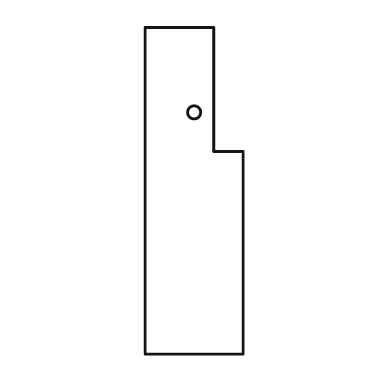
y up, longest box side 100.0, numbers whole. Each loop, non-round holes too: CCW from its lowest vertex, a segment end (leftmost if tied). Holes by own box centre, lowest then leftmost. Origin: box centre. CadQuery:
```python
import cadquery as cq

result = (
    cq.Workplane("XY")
    .moveTo(-15.0, -50.0)
    .lineTo(15.0, -50.0)
    .lineTo(15.0, 12.0)
    .lineTo(6.0, 12.0)
    .lineTo(6.0, 50.0)
    .lineTo(-15.0, 50.0)
    .close()
    .moveTo(0.0, 24.0)
    .circle(2.0)
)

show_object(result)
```